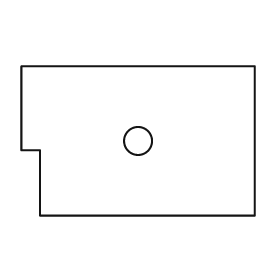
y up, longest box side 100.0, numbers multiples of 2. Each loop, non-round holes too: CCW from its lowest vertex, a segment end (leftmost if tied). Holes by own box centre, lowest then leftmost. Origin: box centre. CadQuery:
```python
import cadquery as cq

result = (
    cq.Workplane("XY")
    .moveTo(-42.0, -32.0)
    .lineTo(50.0, -32.0)
    .lineTo(50.0, 32.0)
    .lineTo(-50.0, 32.0)
    .lineTo(-50.0, -4.0)
    .lineTo(-42.0, -4.0)
    .close()
    .moveTo(0.0, 0.0)
    .circle(6.0)
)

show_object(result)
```